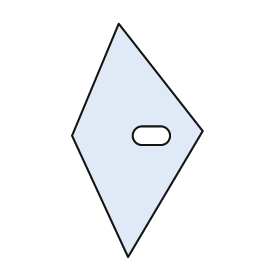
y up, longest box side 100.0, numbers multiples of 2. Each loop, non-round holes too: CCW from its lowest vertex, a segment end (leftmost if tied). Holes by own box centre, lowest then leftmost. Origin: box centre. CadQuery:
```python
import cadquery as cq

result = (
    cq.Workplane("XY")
    .moveTo(-4.0, -50.0)
    .lineTo(28.0, 4.0)
    .lineTo(-8.0, 50.0)
    .lineTo(-28.0, 2.0)
    .close()
    .moveTo(2.0, -2.0)
    .lineTo(10.0, -2.0)
    .threePointArc((14.0, 2.0), (10.0, 6.0))
    .lineTo(2.0, 6.0)
    .threePointArc((-2.0, 2.0), (2.0, -2.0))
    .close()
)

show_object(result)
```